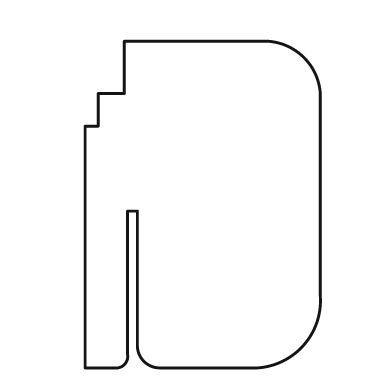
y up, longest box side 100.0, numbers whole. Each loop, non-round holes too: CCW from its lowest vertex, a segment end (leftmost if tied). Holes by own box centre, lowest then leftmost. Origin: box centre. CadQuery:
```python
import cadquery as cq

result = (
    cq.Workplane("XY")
    .moveTo(-36.0, -50.0)
    .lineTo(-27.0, -50.0)
    .threePointArc((-24.0, -49.0), (-23.0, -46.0))
    .lineTo(-23.0, -2.0)
    .lineTo(-20.0, -2.0)
    .lineTo(-20.0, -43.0)
    .threePointArc((-18.0, -48.0), (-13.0, -50.0))
    .lineTo(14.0, -50.0)
    .threePointArc((30.0, -44.0), (36.0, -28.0))
    .lineTo(36.0, 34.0)
    .threePointArc((31.0, 45.0), (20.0, 50.0))
    .lineTo(-24.0, 50.0)
    .lineTo(-24.0, 34.0)
    .lineTo(-32.0, 34.0)
    .lineTo(-32.0, 24.0)
    .lineTo(-36.0, 24.0)
    .close()
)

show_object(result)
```